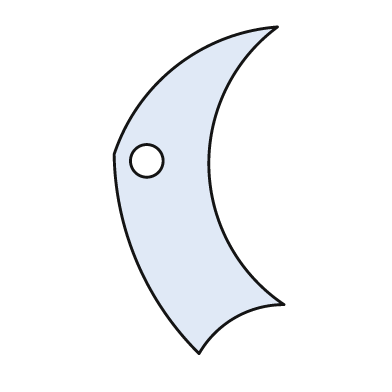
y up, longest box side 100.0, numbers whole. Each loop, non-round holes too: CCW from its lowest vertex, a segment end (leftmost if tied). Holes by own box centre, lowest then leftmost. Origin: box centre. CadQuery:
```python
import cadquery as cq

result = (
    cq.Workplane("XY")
    .moveTo(0.0, -50.0)
    .threePointArc((11.0, -39.0), (26.0, -35.0))
    .threePointArc((3.0, 7.0), (24.0, 50.0))
    .threePointArc((-7.0, 38.0), (-26.0, 11.0))
    .threePointArc((-19.0, -22.0), (0.0, -50.0))
    .close()
    .moveTo(-16.0, 9.0)
    .circle(5.0)
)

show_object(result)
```